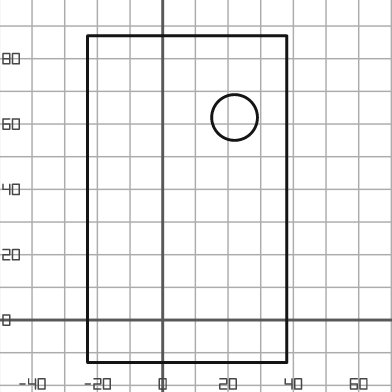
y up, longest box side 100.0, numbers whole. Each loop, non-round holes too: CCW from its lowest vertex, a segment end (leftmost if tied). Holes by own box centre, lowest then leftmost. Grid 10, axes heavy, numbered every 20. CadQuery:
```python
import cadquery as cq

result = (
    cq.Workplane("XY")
    .moveTo(-23.0, -13.0)
    .lineTo(38.0, -13.0)
    .lineTo(38.0, 87.0)
    .lineTo(-23.0, 87.0)
    .close()
    .moveTo(22.0, 62.0)
    .circle(7.0)
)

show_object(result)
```